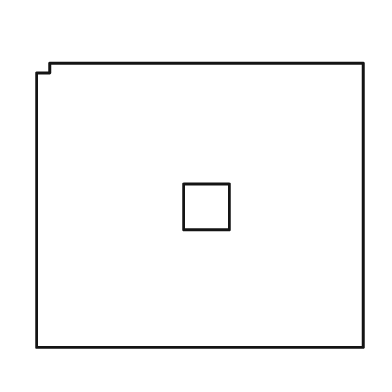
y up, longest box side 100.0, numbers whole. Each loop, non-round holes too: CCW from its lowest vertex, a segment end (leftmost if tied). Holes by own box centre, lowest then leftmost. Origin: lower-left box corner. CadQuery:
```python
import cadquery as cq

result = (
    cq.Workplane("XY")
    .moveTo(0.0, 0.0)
    .lineTo(100.0, 0.0)
    .lineTo(100.0, 87.0)
    .lineTo(4.0, 87.0)
    .lineTo(4.0, 84.0)
    .lineTo(0.0, 84.0)
    .close()
    .moveTo(45.0, 36.0)
    .lineTo(59.0, 36.0)
    .lineTo(59.0, 50.0)
    .lineTo(45.0, 50.0)
    .close()
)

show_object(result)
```